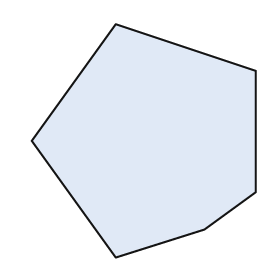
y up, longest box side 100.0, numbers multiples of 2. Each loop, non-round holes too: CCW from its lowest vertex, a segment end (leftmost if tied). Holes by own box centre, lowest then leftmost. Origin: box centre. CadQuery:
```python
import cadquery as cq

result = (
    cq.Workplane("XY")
    .moveTo(-12.0, -50.0)
    .lineTo(26.0, -38.0)
    .lineTo(48.0, -22.0)
    .lineTo(48.0, 30.0)
    .lineTo(-12.0, 50.0)
    .lineTo(-48.0, 0.0)
    .close()
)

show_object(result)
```